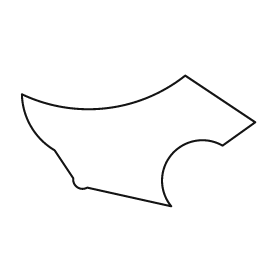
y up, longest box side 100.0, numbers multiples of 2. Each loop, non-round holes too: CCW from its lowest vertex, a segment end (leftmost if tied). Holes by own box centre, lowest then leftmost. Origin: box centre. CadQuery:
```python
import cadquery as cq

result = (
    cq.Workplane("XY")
    .moveTo(14.0, -28.0)
    .threePointArc((14.0, -6.0), (36.0, -2.0))
    .lineTo(50.0, 8.0)
    .lineTo(20.0, 28.0)
    .threePointArc((-14.0, 14.0), (-50.0, 20.0))
    .threePointArc((-46.0, 6.0), (-36.0, -4.0))
    .lineTo(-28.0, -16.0)
    .threePointArc((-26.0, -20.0), (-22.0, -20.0))
    .close()
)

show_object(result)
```